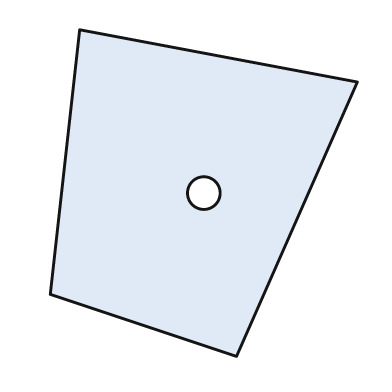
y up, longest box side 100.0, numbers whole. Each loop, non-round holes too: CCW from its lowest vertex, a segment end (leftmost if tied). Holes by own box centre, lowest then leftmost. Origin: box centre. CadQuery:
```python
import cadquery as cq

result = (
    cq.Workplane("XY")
    .moveTo(10.0, -50.0)
    .lineTo(47.0, 34.0)
    .lineTo(-38.0, 50.0)
    .lineTo(-47.0, -31.0)
    .close()
    .moveTo(0.0, 0.0)
    .circle(5.0)
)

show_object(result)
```